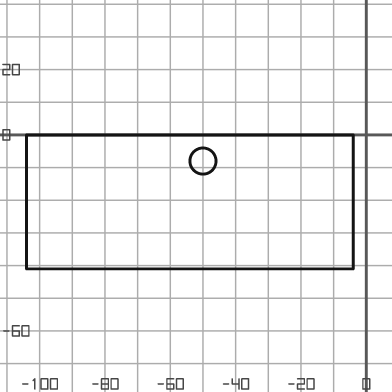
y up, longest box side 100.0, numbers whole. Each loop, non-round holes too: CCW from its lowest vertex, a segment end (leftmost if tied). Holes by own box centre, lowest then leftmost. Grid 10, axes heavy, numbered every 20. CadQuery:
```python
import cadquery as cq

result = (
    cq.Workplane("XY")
    .moveTo(-104.0, -41.0)
    .lineTo(-4.0, -41.0)
    .lineTo(-4.0, 0.0)
    .lineTo(-104.0, 0.0)
    .close()
    .moveTo(-50.0, -8.0)
    .circle(4.0)
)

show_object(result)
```